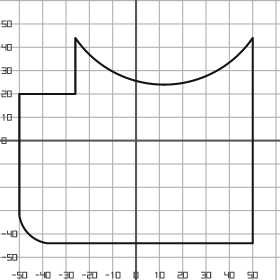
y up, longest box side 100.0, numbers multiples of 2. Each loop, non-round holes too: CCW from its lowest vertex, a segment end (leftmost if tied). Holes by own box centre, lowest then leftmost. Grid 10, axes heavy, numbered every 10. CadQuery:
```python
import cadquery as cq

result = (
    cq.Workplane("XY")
    .moveTo(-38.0, -44.0)
    .lineTo(50.0, -44.0)
    .lineTo(50.0, 44.0)
    .threePointArc((12.0, 24.0), (-26.0, 44.0))
    .lineTo(-26.0, 20.0)
    .lineTo(-50.0, 20.0)
    .lineTo(-50.0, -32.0)
    .threePointArc((-46.0, -40.0), (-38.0, -44.0))
    .close()
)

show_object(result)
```